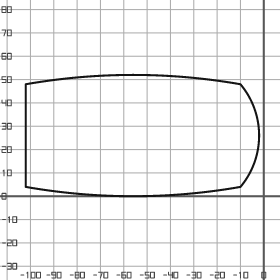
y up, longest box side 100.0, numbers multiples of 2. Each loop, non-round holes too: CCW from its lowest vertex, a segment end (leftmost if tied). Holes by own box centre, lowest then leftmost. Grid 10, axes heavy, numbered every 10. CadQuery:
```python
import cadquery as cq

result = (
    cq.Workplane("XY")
    .moveTo(-102.0, 4.0)
    .threePointArc((-56.0, 0.0), (-10.0, 4.0))
    .threePointArc((-2.0, 26.0), (-10.0, 48.0))
    .threePointArc((-56.0, 52.0), (-102.0, 48.0))
    .close()
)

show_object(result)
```